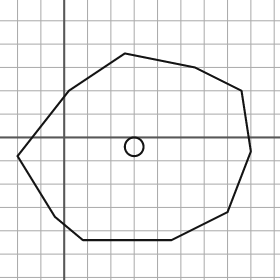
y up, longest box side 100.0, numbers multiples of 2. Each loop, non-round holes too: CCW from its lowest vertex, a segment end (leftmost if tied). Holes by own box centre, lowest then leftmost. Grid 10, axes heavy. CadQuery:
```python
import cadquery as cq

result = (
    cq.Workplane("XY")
    .moveTo(8.0, -44.0)
    .lineTo(46.0, -44.0)
    .lineTo(70.0, -32.0)
    .lineTo(80.0, -6.0)
    .lineTo(76.0, 20.0)
    .lineTo(56.0, 30.0)
    .lineTo(26.0, 36.0)
    .lineTo(2.0, 20.0)
    .lineTo(-20.0, -8.0)
    .lineTo(-4.0, -34.0)
    .close()
    .moveTo(30.0, -4.0)
    .circle(4.0)
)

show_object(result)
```